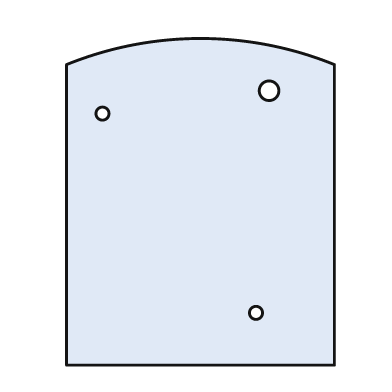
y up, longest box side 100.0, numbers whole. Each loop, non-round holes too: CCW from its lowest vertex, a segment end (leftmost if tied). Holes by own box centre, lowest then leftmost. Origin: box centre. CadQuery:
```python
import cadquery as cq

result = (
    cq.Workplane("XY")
    .moveTo(-41.0, -50.0)
    .lineTo(41.0, -50.0)
    .lineTo(41.0, 42.0)
    .threePointArc((0.0, 50.0), (-41.0, 42.0))
    .close()
    .moveTo(17.0, -34.0)
    .circle(2.0)
    .moveTo(-30.0, 27.0)
    .circle(2.0)
    .moveTo(21.0, 34.0)
    .circle(3.0)
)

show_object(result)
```